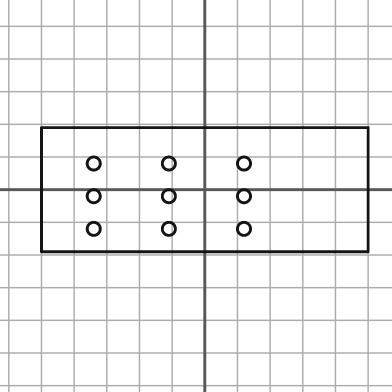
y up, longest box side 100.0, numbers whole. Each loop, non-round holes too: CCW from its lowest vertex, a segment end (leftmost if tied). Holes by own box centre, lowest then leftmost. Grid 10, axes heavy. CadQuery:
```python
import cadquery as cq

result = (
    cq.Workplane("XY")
    .moveTo(-50.0, -19.0)
    .lineTo(50.0, -19.0)
    .lineTo(50.0, 19.0)
    .lineTo(-50.0, 19.0)
    .close()
    .moveTo(-34.0, -12.0)
    .circle(2.0)
    .moveTo(-11.0, -12.0)
    .circle(2.0)
    .moveTo(12.0, -12.0)
    .circle(2.0)
    .moveTo(-34.0, -2.0)
    .circle(2.0)
    .moveTo(-11.0, -2.0)
    .circle(2.0)
    .moveTo(12.0, -2.0)
    .circle(2.0)
    .moveTo(-34.0, 8.0)
    .circle(2.0)
    .moveTo(-11.0, 8.0)
    .circle(2.0)
    .moveTo(12.0, 8.0)
    .circle(2.0)
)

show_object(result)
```